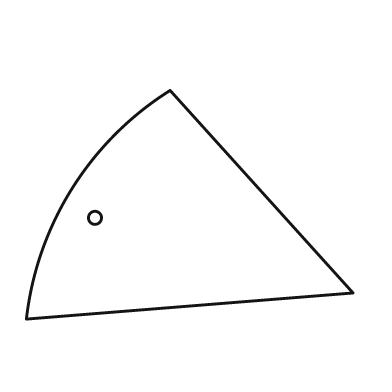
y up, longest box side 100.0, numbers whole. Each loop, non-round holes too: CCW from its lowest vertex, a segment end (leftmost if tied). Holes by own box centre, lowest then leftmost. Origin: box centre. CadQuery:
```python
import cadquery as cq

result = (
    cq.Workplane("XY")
    .moveTo(-50.0, -35.0)
    .lineTo(50.0, -27.0)
    .lineTo(-6.0, 35.0)
    .threePointArc((-36.0, 5.0), (-50.0, -35.0))
    .close()
    .moveTo(-29.0, -4.0)
    .circle(2.0)
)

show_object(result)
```